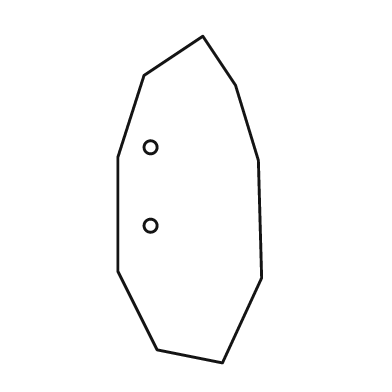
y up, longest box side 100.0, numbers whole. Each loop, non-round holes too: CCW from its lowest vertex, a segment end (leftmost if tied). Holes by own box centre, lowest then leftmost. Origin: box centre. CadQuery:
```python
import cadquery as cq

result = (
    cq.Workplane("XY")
    .moveTo(10.0, -50.0)
    .lineTo(22.0, -24.0)
    .lineTo(21.0, 12.0)
    .lineTo(14.0, 35.0)
    .lineTo(4.0, 50.0)
    .lineTo(-14.0, 38.0)
    .lineTo(-22.0, 13.0)
    .lineTo(-22.0, -22.0)
    .lineTo(-10.0, -46.0)
    .close()
    .moveTo(-12.0, -8.0)
    .circle(2.0)
    .moveTo(-12.0, 16.0)
    .circle(2.0)
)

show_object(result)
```